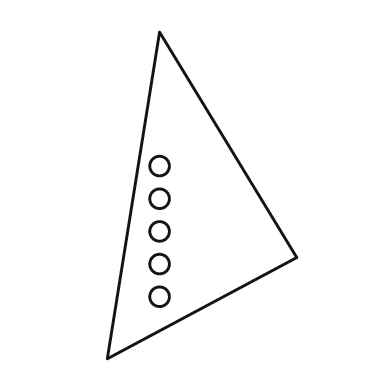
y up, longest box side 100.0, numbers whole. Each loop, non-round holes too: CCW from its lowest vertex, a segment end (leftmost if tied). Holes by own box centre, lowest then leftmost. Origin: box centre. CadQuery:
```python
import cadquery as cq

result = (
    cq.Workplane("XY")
    .moveTo(-29.0, -50.0)
    .lineTo(29.0, -19.0)
    .lineTo(-13.0, 50.0)
    .close()
    .moveTo(-13.0, -31.0)
    .circle(3.0)
    .moveTo(-13.0, -21.0)
    .circle(3.0)
    .moveTo(-13.0, -11.0)
    .circle(3.0)
    .moveTo(-13.0, -1.0)
    .circle(3.0)
    .moveTo(-13.0, 9.0)
    .circle(3.0)
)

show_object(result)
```